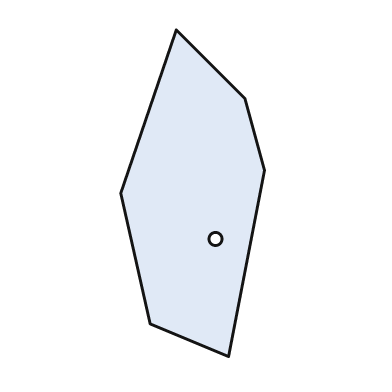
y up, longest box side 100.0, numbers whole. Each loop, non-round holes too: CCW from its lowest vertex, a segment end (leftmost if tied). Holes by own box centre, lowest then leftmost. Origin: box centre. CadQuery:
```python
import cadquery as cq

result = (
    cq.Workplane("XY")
    .moveTo(11.0, -50.0)
    .lineTo(22.0, 7.0)
    .lineTo(16.0, 29.0)
    .lineTo(-5.0, 50.0)
    .lineTo(-22.0, 0.0)
    .lineTo(-13.0, -40.0)
    .close()
    .moveTo(7.0, -14.0)
    .circle(2.0)
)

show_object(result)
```